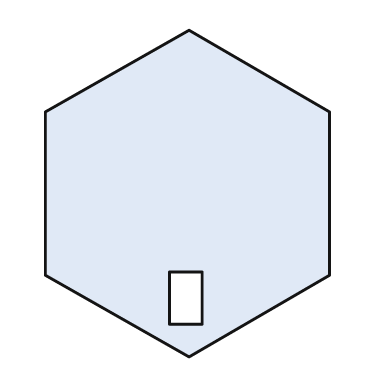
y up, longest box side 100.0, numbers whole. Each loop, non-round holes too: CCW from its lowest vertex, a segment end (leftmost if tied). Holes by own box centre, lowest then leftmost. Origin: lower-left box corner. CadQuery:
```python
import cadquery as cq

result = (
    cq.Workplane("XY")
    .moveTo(44.0, 0.0)
    .lineTo(87.0, 25.0)
    .lineTo(87.0, 75.0)
    .lineTo(44.0, 100.0)
    .lineTo(0.0, 75.0)
    .lineTo(0.0, 25.0)
    .close()
    .moveTo(38.0, 10.0)
    .lineTo(48.0, 10.0)
    .lineTo(48.0, 26.0)
    .lineTo(38.0, 26.0)
    .close()
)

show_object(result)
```